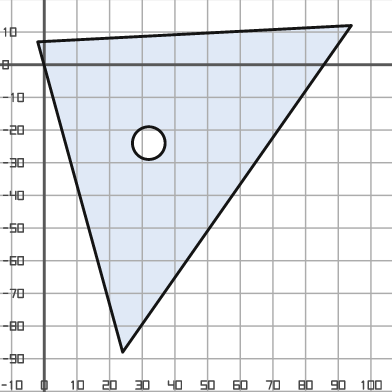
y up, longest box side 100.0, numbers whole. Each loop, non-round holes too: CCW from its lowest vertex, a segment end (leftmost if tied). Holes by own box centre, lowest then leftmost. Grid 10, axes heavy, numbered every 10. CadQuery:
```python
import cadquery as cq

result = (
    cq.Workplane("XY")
    .moveTo(24.0, -88.0)
    .lineTo(94.0, 12.0)
    .lineTo(-2.0, 7.0)
    .close()
    .moveTo(32.0, -24.0)
    .circle(5.0)
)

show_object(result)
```